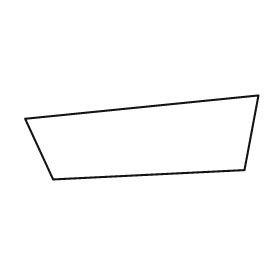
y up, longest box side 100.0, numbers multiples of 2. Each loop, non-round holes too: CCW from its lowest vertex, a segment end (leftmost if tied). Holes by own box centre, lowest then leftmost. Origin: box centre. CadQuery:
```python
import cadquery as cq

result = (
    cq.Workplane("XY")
    .moveTo(-38.0, -18.0)
    .lineTo(44.0, -14.0)
    .lineTo(50.0, 18.0)
    .lineTo(-50.0, 8.0)
    .close()
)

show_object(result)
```